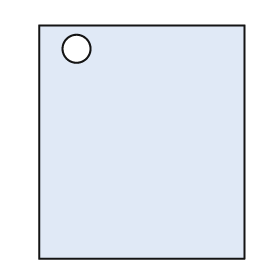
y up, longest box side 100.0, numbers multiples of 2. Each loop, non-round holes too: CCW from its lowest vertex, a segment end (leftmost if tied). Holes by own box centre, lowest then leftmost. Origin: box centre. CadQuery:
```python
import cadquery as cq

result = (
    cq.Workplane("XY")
    .moveTo(-44.0, -50.0)
    .lineTo(44.0, -50.0)
    .lineTo(44.0, 50.0)
    .lineTo(-44.0, 50.0)
    .close()
    .moveTo(-28.0, 40.0)
    .circle(6.0)
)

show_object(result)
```